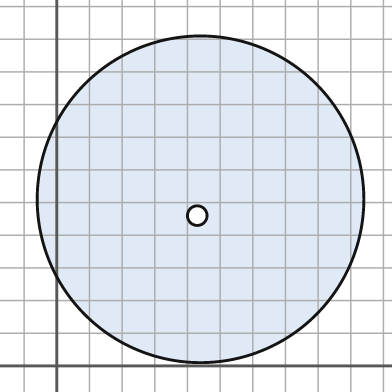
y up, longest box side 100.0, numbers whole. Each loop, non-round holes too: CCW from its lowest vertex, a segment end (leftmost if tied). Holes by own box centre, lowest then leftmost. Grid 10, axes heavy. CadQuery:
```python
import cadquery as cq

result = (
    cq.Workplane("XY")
    .moveTo(44.0, 51.0)
    .circle(50.0)
    .moveTo(43.0, 46.0)
    .circle(3.0)
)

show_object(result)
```